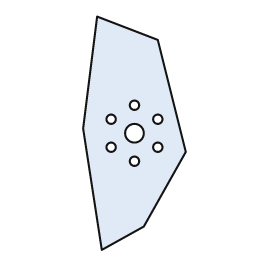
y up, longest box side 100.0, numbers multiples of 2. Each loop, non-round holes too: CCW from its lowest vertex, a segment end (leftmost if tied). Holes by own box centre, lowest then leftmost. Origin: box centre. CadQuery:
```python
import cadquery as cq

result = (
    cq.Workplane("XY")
    .moveTo(-14.0, -50.0)
    .lineTo(4.0, -40.0)
    .lineTo(22.0, -8.0)
    .lineTo(10.0, 40.0)
    .lineTo(-16.0, 50.0)
    .lineTo(-22.0, 2.0)
    .close()
    .moveTo(0.0, -12.0)
    .circle(2.0)
    .moveTo(-10.0, -6.0)
    .circle(2.0)
    .moveTo(10.0, -6.0)
    .circle(2.0)
    .moveTo(0.0, 0.0)
    .circle(4.0)
    .moveTo(-10.0, 6.0)
    .circle(2.0)
    .moveTo(10.0, 6.0)
    .circle(2.0)
    .moveTo(0.0, 12.0)
    .circle(2.0)
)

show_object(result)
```